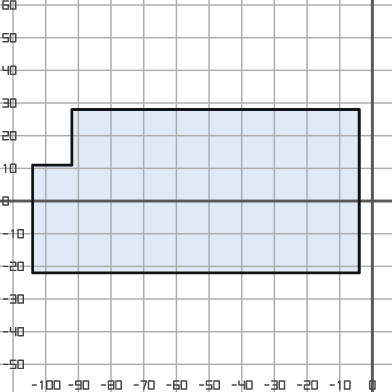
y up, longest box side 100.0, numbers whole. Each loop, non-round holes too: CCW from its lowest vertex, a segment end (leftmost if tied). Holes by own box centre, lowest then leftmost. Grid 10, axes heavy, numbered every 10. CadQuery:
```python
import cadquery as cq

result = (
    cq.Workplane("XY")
    .moveTo(-104.0, -22.0)
    .lineTo(-4.0, -22.0)
    .lineTo(-4.0, 28.0)
    .lineTo(-92.0, 28.0)
    .lineTo(-92.0, 11.0)
    .lineTo(-104.0, 11.0)
    .close()
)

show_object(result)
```